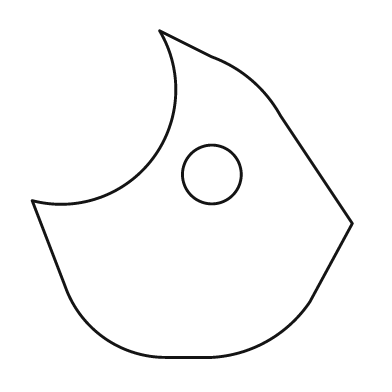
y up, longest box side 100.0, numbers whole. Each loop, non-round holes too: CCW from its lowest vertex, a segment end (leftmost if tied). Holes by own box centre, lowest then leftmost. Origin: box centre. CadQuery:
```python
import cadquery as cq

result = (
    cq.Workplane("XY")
    .moveTo(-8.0, -50.0)
    .lineTo(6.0, -50.0)
    .threePointArc((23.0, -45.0), (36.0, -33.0))
    .lineTo(49.0, -9.0)
    .lineTo(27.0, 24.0)
    .threePointArc((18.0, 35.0), (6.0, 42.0))
    .lineTo(-10.0, 50.0)
    .threePointArc((-12.0, 11.0), (-49.0, -2.0))
    .lineTo(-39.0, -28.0)
    .threePointArc((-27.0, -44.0), (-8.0, -50.0))
    .close()
    .moveTo(6.0, 6.0)
    .circle(9.0)
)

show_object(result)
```